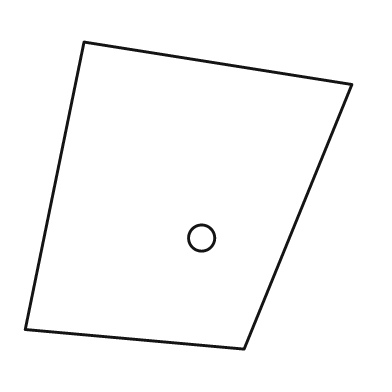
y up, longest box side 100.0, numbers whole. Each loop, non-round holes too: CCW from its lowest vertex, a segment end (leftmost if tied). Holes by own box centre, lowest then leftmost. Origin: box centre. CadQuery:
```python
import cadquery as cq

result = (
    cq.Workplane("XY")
    .moveTo(17.0, -47.0)
    .lineTo(50.0, 34.0)
    .lineTo(-32.0, 47.0)
    .lineTo(-50.0, -41.0)
    .close()
    .moveTo(4.0, -13.0)
    .circle(4.0)
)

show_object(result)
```